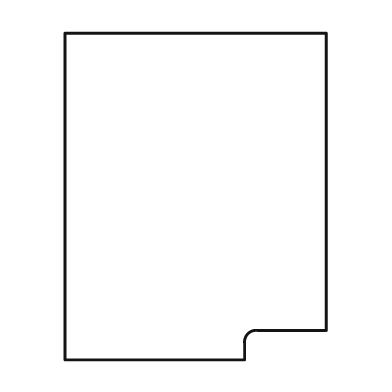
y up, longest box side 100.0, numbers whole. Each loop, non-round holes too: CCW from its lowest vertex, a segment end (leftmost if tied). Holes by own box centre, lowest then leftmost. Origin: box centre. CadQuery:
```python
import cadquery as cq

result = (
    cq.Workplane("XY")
    .moveTo(-40.0, -50.0)
    .lineTo(15.0, -50.0)
    .lineTo(15.0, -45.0)
    .threePointArc((16.0, -42.0), (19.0, -41.0))
    .lineTo(40.0, -41.0)
    .lineTo(40.0, 50.0)
    .lineTo(-40.0, 50.0)
    .close()
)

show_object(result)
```